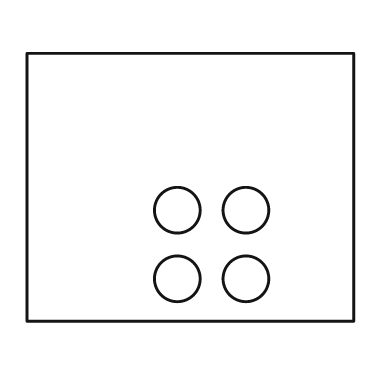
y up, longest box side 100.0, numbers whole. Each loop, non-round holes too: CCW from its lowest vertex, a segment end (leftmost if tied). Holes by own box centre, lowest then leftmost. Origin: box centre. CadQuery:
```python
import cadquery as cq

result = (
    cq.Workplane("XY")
    .moveTo(-50.0, -41.0)
    .lineTo(50.0, -41.0)
    .lineTo(50.0, 41.0)
    .lineTo(-50.0, 41.0)
    .close()
    .moveTo(-4.0, -28.0)
    .circle(7.0)
    .moveTo(17.0, -28.0)
    .circle(7.0)
    .moveTo(-4.0, -7.0)
    .circle(7.0)
    .moveTo(17.0, -7.0)
    .circle(7.0)
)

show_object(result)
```